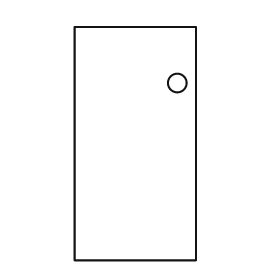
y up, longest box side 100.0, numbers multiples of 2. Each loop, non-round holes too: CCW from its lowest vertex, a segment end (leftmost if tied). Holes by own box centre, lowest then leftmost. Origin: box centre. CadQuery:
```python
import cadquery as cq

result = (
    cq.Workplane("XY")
    .moveTo(-26.0, -50.0)
    .lineTo(26.0, -50.0)
    .lineTo(26.0, 50.0)
    .lineTo(-26.0, 50.0)
    .close()
    .moveTo(18.0, 26.0)
    .circle(4.0)
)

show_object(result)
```